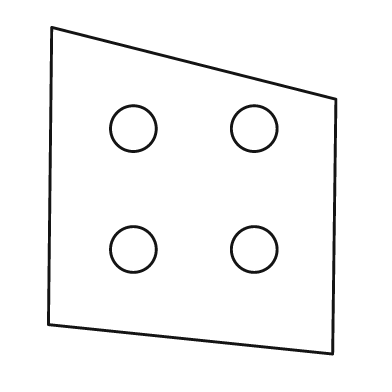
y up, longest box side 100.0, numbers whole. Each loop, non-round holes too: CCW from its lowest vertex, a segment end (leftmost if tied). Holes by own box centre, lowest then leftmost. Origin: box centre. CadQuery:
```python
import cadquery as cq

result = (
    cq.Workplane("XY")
    .moveTo(43.0, -50.0)
    .lineTo(44.0, 28.0)
    .lineTo(-43.0, 50.0)
    .lineTo(-44.0, -41.0)
    .close()
    .moveTo(-18.0, -18.0)
    .circle(7.0)
    .moveTo(19.0, -18.0)
    .circle(7.0)
    .moveTo(-18.0, 19.0)
    .circle(7.0)
    .moveTo(19.0, 19.0)
    .circle(7.0)
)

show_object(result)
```